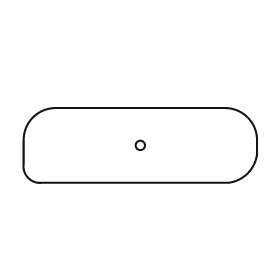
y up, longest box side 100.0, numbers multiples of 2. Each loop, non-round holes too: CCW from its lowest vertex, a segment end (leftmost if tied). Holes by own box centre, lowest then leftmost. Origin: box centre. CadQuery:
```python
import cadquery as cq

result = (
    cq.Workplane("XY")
    .moveTo(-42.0, -16.0)
    .lineTo(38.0, -16.0)
    .threePointArc((46.0, -12.0), (50.0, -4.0))
    .lineTo(50.0, 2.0)
    .threePointArc((46.0, 12.0), (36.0, 16.0))
    .lineTo(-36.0, 16.0)
    .threePointArc((-46.0, 12.0), (-50.0, 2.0))
    .lineTo(-50.0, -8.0)
    .threePointArc((-48.0, -14.0), (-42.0, -16.0))
    .close()
    .moveTo(0.0, 0.0)
    .circle(2.0)
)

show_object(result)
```